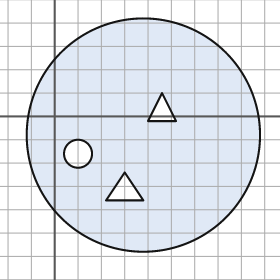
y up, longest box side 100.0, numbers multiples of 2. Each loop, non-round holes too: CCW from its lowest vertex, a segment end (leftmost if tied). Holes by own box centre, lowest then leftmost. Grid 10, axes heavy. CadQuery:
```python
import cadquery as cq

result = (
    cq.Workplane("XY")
    .moveTo(38.0, -8.0)
    .circle(50.0)
    .moveTo(22.0, -36.0)
    .lineTo(38.0, -36.0)
    .lineTo(30.0, -24.0)
    .close()
    .moveTo(10.0, -16.0)
    .circle(6.0)
    .moveTo(40.0, -2.0)
    .lineTo(52.0, -2.0)
    .lineTo(46.0, 10.0)
    .close()
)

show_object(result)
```